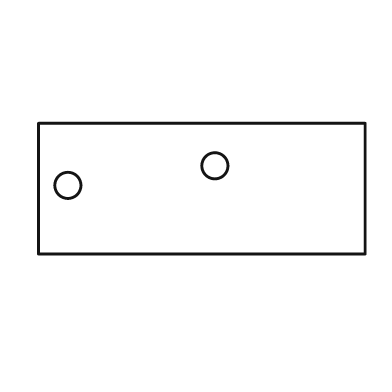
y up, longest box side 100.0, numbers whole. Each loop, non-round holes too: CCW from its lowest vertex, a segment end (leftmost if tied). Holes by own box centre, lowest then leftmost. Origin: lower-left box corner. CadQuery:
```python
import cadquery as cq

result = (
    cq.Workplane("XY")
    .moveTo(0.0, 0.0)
    .lineTo(100.0, 0.0)
    .lineTo(100.0, 40.0)
    .lineTo(0.0, 40.0)
    .close()
    .moveTo(9.0, 21.0)
    .circle(4.0)
    .moveTo(54.0, 27.0)
    .circle(4.0)
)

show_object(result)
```